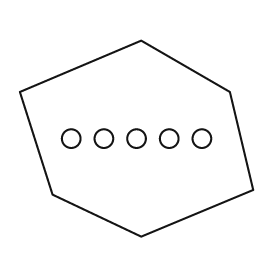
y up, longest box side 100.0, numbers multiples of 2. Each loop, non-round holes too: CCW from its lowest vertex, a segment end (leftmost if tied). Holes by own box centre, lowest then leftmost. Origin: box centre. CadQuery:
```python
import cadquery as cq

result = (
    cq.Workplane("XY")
    .moveTo(2.0, -42.0)
    .lineTo(50.0, -22.0)
    .lineTo(40.0, 20.0)
    .lineTo(2.0, 42.0)
    .lineTo(-50.0, 20.0)
    .lineTo(-36.0, -24.0)
    .close()
    .moveTo(-28.0, 0.0)
    .circle(4.0)
    .moveTo(-14.0, 0.0)
    .circle(4.0)
    .moveTo(0.0, 0.0)
    .circle(4.0)
    .moveTo(14.0, 0.0)
    .circle(4.0)
    .moveTo(28.0, 0.0)
    .circle(4.0)
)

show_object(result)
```